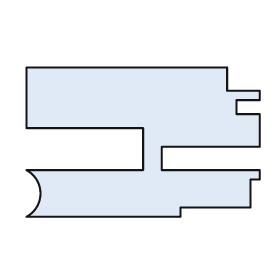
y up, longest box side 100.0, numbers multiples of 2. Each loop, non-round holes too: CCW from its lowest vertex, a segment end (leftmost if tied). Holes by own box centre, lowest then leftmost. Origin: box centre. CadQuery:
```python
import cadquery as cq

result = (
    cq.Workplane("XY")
    .moveTo(-50.0, -32.0)
    .lineTo(16.0, -32.0)
    .lineTo(16.0, -28.0)
    .lineTo(46.0, -28.0)
    .lineTo(46.0, -16.0)
    .lineTo(50.0, -16.0)
    .lineTo(50.0, -12.0)
    .lineTo(8.0, -12.0)
    .lineTo(8.0, -2.0)
    .lineTo(50.0, -2.0)
    .lineTo(50.0, 12.0)
    .lineTo(40.0, 12.0)
    .lineTo(40.0, 18.0)
    .lineTo(50.0, 18.0)
    .lineTo(50.0, 22.0)
    .lineTo(36.0, 22.0)
    .lineTo(36.0, 32.0)
    .lineTo(-50.0, 32.0)
    .lineTo(-50.0, 6.0)
    .lineTo(0.0, 6.0)
    .lineTo(0.0, -12.0)
    .lineTo(-50.0, -12.0)
    .threePointArc((-44.0, -22.0), (-50.0, -32.0))
    .close()
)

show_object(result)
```